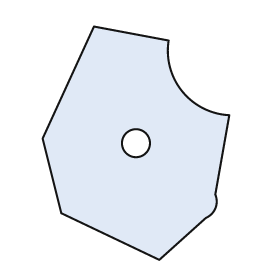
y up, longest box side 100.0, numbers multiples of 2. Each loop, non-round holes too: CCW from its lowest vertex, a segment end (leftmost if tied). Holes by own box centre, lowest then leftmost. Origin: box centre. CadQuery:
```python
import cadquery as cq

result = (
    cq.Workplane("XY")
    .moveTo(10.0, -50.0)
    .lineTo(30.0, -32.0)
    .threePointArc((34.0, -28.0), (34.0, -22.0))
    .lineTo(40.0, 12.0)
    .threePointArc((20.0, 22.0), (14.0, 44.0))
    .lineTo(-18.0, 50.0)
    .lineTo(-40.0, 2.0)
    .lineTo(-32.0, -30.0)
    .close()
    .moveTo(0.0, 0.0)
    .circle(6.0)
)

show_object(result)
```